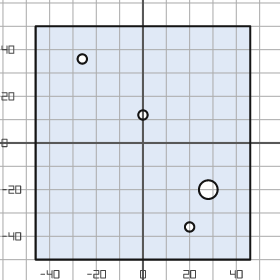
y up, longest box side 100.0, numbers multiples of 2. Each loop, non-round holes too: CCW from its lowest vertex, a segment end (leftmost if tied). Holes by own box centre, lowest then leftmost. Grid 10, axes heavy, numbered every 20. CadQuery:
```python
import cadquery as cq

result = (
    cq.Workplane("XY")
    .moveTo(-46.0, -50.0)
    .lineTo(46.0, -50.0)
    .lineTo(46.0, 50.0)
    .lineTo(-46.0, 50.0)
    .close()
    .moveTo(20.0, -36.0)
    .circle(2.0)
    .moveTo(28.0, -20.0)
    .circle(4.0)
    .moveTo(0.0, 12.0)
    .circle(2.0)
    .moveTo(-26.0, 36.0)
    .circle(2.0)
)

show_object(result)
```